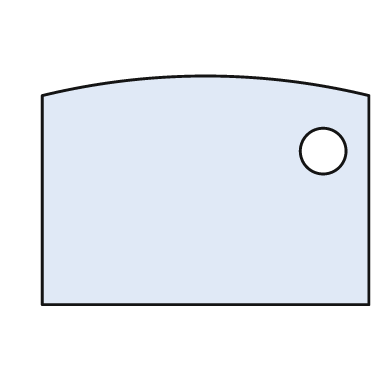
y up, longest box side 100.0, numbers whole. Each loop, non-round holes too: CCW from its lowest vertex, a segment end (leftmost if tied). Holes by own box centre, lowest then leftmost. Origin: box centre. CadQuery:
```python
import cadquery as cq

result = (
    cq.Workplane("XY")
    .moveTo(-50.0, -35.0)
    .lineTo(50.0, -35.0)
    .lineTo(50.0, 29.0)
    .threePointArc((0.0, 35.0), (-50.0, 29.0))
    .close()
    .moveTo(36.0, 12.0)
    .circle(7.0)
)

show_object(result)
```